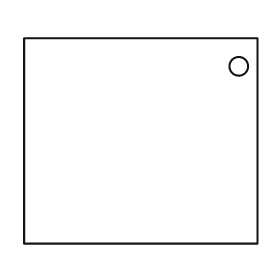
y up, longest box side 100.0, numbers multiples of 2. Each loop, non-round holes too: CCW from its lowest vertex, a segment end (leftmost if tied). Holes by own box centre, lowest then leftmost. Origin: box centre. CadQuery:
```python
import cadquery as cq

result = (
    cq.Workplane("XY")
    .moveTo(-50.0, -44.0)
    .lineTo(50.0, -44.0)
    .lineTo(50.0, 44.0)
    .lineTo(-50.0, 44.0)
    .close()
    .moveTo(42.0, 32.0)
    .circle(4.0)
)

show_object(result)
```